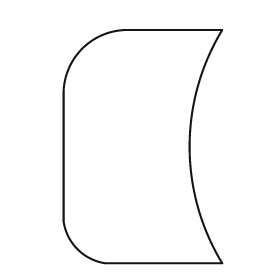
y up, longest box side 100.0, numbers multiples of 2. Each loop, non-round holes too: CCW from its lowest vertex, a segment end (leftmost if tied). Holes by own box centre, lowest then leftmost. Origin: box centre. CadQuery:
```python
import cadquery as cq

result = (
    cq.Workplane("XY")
    .moveTo(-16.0, -50.0)
    .lineTo(34.0, -50.0)
    .threePointArc((20.0, 0.0), (34.0, 50.0))
    .lineTo(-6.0, 50.0)
    .threePointArc((-26.0, 42.0), (-34.0, 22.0))
    .lineTo(-34.0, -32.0)
    .threePointArc((-28.0, -44.0), (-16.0, -50.0))
    .close()
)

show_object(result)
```